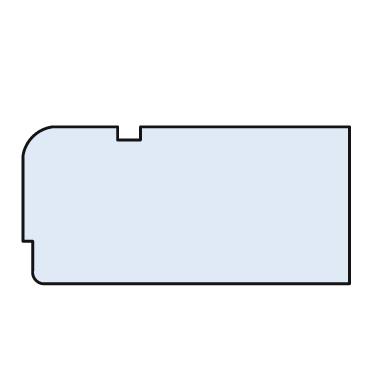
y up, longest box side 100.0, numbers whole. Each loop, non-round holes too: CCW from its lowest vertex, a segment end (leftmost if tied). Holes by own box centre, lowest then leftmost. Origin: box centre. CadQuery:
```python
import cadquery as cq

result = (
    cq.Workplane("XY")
    .moveTo(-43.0, -24.0)
    .lineTo(50.0, -24.0)
    .lineTo(50.0, 24.0)
    .lineTo(-14.0, 24.0)
    .lineTo(-14.0, 20.0)
    .lineTo(-21.0, 20.0)
    .lineTo(-21.0, 24.0)
    .lineTo(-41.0, 24.0)
    .threePointArc((-47.0, 21.0), (-50.0, 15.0))
    .lineTo(-50.0, -11.0)
    .lineTo(-47.0, -11.0)
    .lineTo(-47.0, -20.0)
    .threePointArc((-46.0, -23.0), (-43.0, -24.0))
    .close()
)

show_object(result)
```